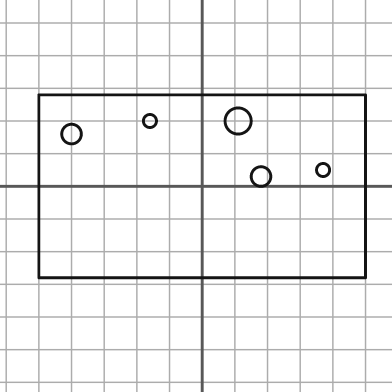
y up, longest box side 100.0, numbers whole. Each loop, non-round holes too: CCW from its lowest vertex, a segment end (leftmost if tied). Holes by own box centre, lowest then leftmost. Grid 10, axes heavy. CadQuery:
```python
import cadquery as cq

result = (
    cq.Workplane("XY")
    .moveTo(-50.0, -28.0)
    .lineTo(50.0, -28.0)
    .lineTo(50.0, 28.0)
    .lineTo(-50.0, 28.0)
    .close()
    .moveTo(18.0, 3.0)
    .circle(3.0)
    .moveTo(37.0, 5.0)
    .circle(2.0)
    .moveTo(-40.0, 16.0)
    .circle(3.0)
    .moveTo(-16.0, 20.0)
    .circle(2.0)
    .moveTo(11.0, 20.0)
    .circle(4.0)
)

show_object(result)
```